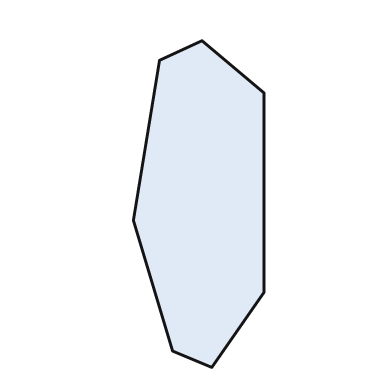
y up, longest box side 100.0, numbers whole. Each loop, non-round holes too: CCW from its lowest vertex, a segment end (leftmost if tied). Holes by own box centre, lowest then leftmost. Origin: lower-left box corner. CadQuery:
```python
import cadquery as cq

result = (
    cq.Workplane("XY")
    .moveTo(24.0, 0.0)
    .lineTo(40.0, 23.0)
    .lineTo(40.0, 84.0)
    .lineTo(21.0, 100.0)
    .lineTo(8.0, 94.0)
    .lineTo(0.0, 45.0)
    .lineTo(12.0, 5.0)
    .close()
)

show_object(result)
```